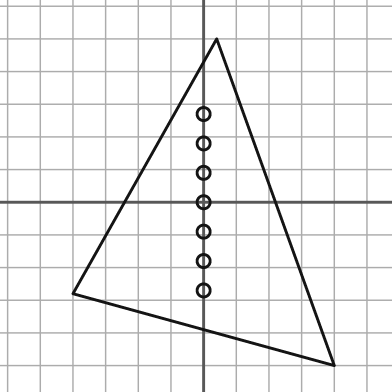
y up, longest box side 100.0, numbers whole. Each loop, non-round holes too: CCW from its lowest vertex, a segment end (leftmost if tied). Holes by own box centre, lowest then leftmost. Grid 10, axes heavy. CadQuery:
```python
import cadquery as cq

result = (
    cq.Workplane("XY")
    .moveTo(40.0, -50.0)
    .lineTo(4.0, 50.0)
    .lineTo(-40.0, -28.0)
    .close()
    .moveTo(0.0, -27.0)
    .circle(2.0)
    .moveTo(0.0, -18.0)
    .circle(2.0)
    .moveTo(0.0, -9.0)
    .circle(2.0)
    .moveTo(0.0, 0.0)
    .circle(2.0)
    .moveTo(0.0, 9.0)
    .circle(2.0)
    .moveTo(0.0, 18.0)
    .circle(2.0)
    .moveTo(0.0, 27.0)
    .circle(2.0)
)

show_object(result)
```